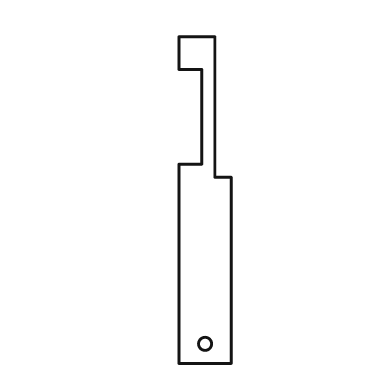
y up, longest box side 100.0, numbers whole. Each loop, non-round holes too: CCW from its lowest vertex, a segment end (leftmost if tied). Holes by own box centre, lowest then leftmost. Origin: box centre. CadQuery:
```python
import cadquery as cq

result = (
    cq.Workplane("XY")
    .moveTo(-8.0, -50.0)
    .lineTo(8.0, -50.0)
    .lineTo(8.0, 7.0)
    .lineTo(3.0, 7.0)
    .lineTo(3.0, 50.0)
    .lineTo(-8.0, 50.0)
    .lineTo(-8.0, 40.0)
    .lineTo(-1.0, 40.0)
    .lineTo(-1.0, 11.0)
    .lineTo(-8.0, 11.0)
    .close()
    .moveTo(0.0, -44.0)
    .circle(2.0)
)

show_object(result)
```